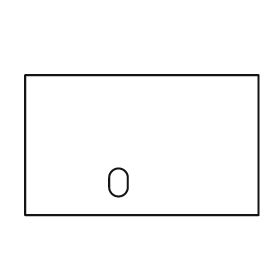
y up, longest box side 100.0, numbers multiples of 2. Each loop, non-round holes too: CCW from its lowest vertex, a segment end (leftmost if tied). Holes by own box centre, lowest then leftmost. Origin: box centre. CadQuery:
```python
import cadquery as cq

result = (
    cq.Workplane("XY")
    .moveTo(-50.0, -30.0)
    .lineTo(50.0, -30.0)
    .lineTo(50.0, 30.0)
    .lineTo(-50.0, 30.0)
    .close()
    .moveTo(-14.0, -18.0)
    .threePointArc((-10.0, -22.0), (-6.0, -18.0))
    .lineTo(-6.0, -14.0)
    .threePointArc((-10.0, -10.0), (-14.0, -14.0))
    .close()
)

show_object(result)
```